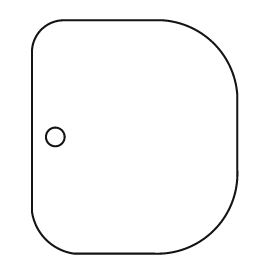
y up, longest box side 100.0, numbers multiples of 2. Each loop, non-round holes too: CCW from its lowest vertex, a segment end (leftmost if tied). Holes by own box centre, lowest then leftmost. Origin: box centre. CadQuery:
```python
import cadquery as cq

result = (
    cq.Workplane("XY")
    .moveTo(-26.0, -50.0)
    .lineTo(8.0, -50.0)
    .threePointArc((34.0, -40.0), (44.0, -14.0))
    .lineTo(44.0, 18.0)
    .threePointArc((34.0, 40.0), (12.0, 50.0))
    .lineTo(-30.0, 50.0)
    .threePointArc((-40.0, 46.0), (-44.0, 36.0))
    .lineTo(-44.0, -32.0)
    .threePointArc((-38.0, -44.0), (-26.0, -50.0))
    .close()
    .moveTo(-34.0, 0.0)
    .circle(4.0)
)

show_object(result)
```